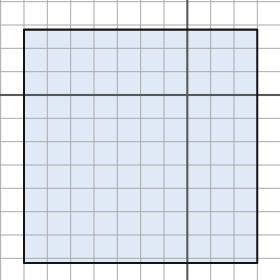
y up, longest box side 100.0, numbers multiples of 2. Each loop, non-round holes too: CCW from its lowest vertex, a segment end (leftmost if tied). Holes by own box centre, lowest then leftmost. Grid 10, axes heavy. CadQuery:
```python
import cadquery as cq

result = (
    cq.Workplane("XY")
    .moveTo(-70.0, -72.0)
    .lineTo(30.0, -72.0)
    .lineTo(30.0, 28.0)
    .lineTo(-70.0, 28.0)
    .close()
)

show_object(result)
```